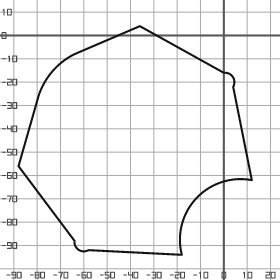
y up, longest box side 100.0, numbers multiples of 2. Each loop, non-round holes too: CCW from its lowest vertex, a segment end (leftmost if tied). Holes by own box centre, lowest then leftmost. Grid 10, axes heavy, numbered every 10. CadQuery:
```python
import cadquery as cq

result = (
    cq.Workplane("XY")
    .moveTo(-18.0, -94.0)
    .threePointArc((-12.0, -70.0), (12.0, -62.0))
    .lineTo(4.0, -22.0)
    .threePointArc((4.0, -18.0), (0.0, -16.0))
    .lineTo(-36.0, 4.0)
    .lineTo(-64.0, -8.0)
    .threePointArc((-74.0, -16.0), (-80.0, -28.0))
    .lineTo(-88.0, -56.0)
    .lineTo(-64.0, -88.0)
    .threePointArc((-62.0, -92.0), (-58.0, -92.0))
    .close()
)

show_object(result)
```